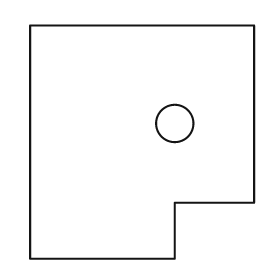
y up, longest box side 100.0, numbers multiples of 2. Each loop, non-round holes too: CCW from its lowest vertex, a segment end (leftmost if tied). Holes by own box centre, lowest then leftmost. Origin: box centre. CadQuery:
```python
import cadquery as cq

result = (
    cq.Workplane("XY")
    .moveTo(-48.0, -50.0)
    .lineTo(14.0, -50.0)
    .lineTo(14.0, -26.0)
    .lineTo(48.0, -26.0)
    .lineTo(48.0, 50.0)
    .lineTo(-48.0, 50.0)
    .close()
    .moveTo(14.0, 8.0)
    .circle(8.0)
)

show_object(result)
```